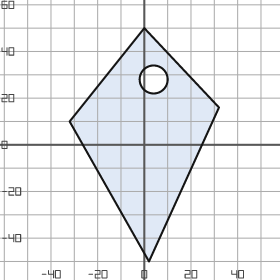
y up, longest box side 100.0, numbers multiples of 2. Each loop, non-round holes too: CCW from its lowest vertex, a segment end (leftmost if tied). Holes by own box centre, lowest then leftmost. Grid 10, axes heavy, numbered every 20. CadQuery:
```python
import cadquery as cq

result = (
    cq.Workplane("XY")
    .moveTo(2.0, -50.0)
    .lineTo(32.0, 16.0)
    .lineTo(0.0, 50.0)
    .lineTo(-32.0, 10.0)
    .close()
    .moveTo(4.0, 28.0)
    .circle(6.0)
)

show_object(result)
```